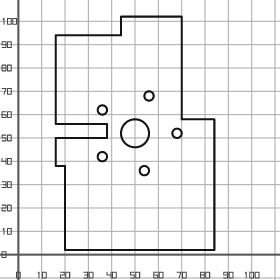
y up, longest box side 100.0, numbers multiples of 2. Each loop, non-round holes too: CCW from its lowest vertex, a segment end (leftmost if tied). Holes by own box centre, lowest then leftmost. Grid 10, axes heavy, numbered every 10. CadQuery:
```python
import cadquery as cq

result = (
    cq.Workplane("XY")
    .moveTo(20.0, 2.0)
    .lineTo(84.0, 2.0)
    .lineTo(84.0, 58.0)
    .lineTo(70.0, 58.0)
    .lineTo(70.0, 102.0)
    .lineTo(44.0, 102.0)
    .lineTo(44.0, 94.0)
    .lineTo(16.0, 94.0)
    .lineTo(16.0, 56.0)
    .lineTo(38.0, 56.0)
    .lineTo(38.0, 50.0)
    .lineTo(16.0, 50.0)
    .lineTo(16.0, 38.0)
    .lineTo(20.0, 38.0)
    .close()
    .moveTo(54.0, 36.0)
    .circle(2.0)
    .moveTo(36.0, 42.0)
    .circle(2.0)
    .moveTo(50.0, 52.0)
    .circle(6.0)
    .moveTo(68.0, 52.0)
    .circle(2.0)
    .moveTo(36.0, 62.0)
    .circle(2.0)
    .moveTo(56.0, 68.0)
    .circle(2.0)
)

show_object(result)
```